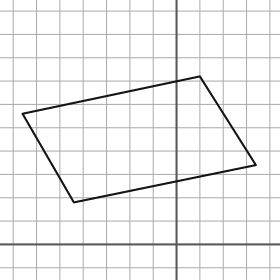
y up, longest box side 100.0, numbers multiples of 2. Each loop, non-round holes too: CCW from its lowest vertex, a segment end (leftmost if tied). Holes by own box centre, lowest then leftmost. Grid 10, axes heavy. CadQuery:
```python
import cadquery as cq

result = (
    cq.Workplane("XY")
    .moveTo(-44.0, 18.0)
    .lineTo(34.0, 34.0)
    .lineTo(10.0, 72.0)
    .lineTo(-66.0, 56.0)
    .close()
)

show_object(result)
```